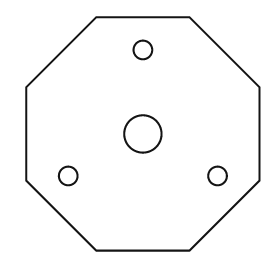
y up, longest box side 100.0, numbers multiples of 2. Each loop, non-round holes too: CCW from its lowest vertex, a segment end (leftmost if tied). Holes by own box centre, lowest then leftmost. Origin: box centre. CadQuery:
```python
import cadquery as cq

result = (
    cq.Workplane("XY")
    .moveTo(-20.0, -50.0)
    .lineTo(20.0, -50.0)
    .lineTo(50.0, -20.0)
    .lineTo(50.0, 20.0)
    .lineTo(20.0, 50.0)
    .lineTo(-20.0, 50.0)
    .lineTo(-50.0, 20.0)
    .lineTo(-50.0, -20.0)
    .close()
    .moveTo(-32.0, -18.0)
    .circle(4.0)
    .moveTo(32.0, -18.0)
    .circle(4.0)
    .moveTo(0.0, 0.0)
    .circle(8.0)
    .moveTo(0.0, 36.0)
    .circle(4.0)
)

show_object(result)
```